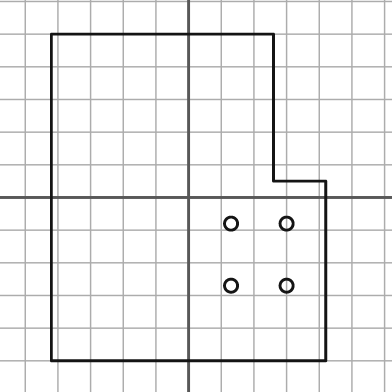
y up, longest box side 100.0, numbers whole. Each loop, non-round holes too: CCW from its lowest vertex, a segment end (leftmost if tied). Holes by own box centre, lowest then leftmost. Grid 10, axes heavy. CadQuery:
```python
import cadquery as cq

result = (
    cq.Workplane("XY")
    .moveTo(-42.0, -50.0)
    .lineTo(42.0, -50.0)
    .lineTo(42.0, 5.0)
    .lineTo(26.0, 5.0)
    .lineTo(26.0, 50.0)
    .lineTo(-42.0, 50.0)
    .close()
    .moveTo(13.0, -27.0)
    .circle(2.0)
    .moveTo(30.0, -27.0)
    .circle(2.0)
    .moveTo(13.0, -8.0)
    .circle(2.0)
    .moveTo(30.0, -8.0)
    .circle(2.0)
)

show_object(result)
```